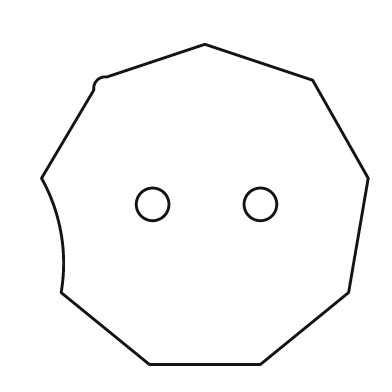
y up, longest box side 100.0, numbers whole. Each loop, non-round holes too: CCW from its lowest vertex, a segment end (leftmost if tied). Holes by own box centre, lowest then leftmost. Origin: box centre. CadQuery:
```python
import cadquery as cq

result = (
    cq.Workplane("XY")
    .moveTo(-17.0, -49.0)
    .lineTo(17.0, -49.0)
    .lineTo(44.0, -27.0)
    .lineTo(50.0, 8.0)
    .lineTo(33.0, 38.0)
    .lineTo(0.0, 49.0)
    .lineTo(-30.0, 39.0)
    .threePointArc((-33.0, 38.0), (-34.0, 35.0))
    .lineTo(-50.0, 8.0)
    .threePointArc((-44.0, -9.0), (-44.0, -27.0))
    .close()
    .moveTo(-16.0, 0.0)
    .circle(5.0)
    .moveTo(17.0, 0.0)
    .circle(5.0)
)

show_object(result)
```